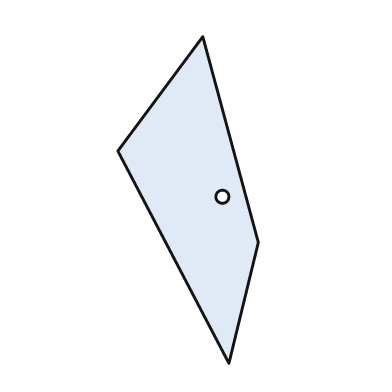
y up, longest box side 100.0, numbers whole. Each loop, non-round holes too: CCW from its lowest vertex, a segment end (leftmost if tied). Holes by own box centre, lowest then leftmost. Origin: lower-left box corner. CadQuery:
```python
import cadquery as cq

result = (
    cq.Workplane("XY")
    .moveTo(34.0, 0.0)
    .lineTo(43.0, 37.0)
    .lineTo(26.0, 100.0)
    .lineTo(0.0, 65.0)
    .close()
    .moveTo(32.0, 51.0)
    .circle(2.0)
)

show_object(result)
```